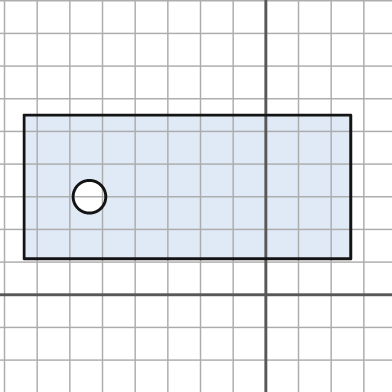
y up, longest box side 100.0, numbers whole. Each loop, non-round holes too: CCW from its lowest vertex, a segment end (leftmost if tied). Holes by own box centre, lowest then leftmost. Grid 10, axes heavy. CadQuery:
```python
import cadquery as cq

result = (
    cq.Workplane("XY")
    .moveTo(-74.0, 11.0)
    .lineTo(26.0, 11.0)
    .lineTo(26.0, 55.0)
    .lineTo(-74.0, 55.0)
    .close()
    .moveTo(-54.0, 30.0)
    .circle(5.0)
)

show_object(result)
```